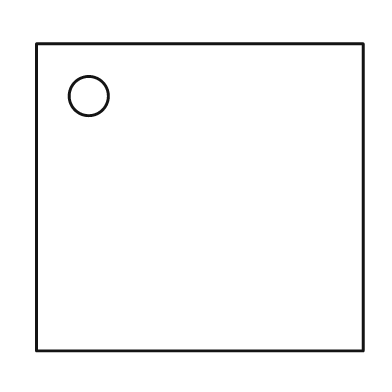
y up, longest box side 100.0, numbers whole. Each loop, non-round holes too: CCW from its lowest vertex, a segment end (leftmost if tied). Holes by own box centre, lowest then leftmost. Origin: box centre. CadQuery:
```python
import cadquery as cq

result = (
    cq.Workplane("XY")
    .moveTo(-50.0, -47.0)
    .lineTo(50.0, -47.0)
    .lineTo(50.0, 47.0)
    .lineTo(-50.0, 47.0)
    .close()
    .moveTo(-34.0, 31.0)
    .circle(6.0)
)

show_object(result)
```